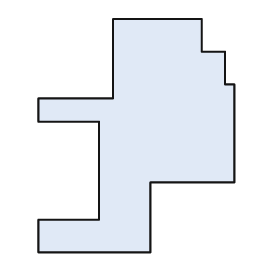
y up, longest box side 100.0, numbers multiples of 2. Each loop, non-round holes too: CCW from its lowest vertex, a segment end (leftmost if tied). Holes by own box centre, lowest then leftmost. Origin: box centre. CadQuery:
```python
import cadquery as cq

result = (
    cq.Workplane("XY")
    .moveTo(-42.0, -50.0)
    .lineTo(6.0, -50.0)
    .lineTo(6.0, -20.0)
    .lineTo(42.0, -20.0)
    .lineTo(42.0, 22.0)
    .lineTo(38.0, 22.0)
    .lineTo(38.0, 36.0)
    .lineTo(28.0, 36.0)
    .lineTo(28.0, 50.0)
    .lineTo(-10.0, 50.0)
    .lineTo(-10.0, 16.0)
    .lineTo(-42.0, 16.0)
    .lineTo(-42.0, 6.0)
    .lineTo(-16.0, 6.0)
    .lineTo(-16.0, -36.0)
    .lineTo(-42.0, -36.0)
    .close()
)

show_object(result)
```